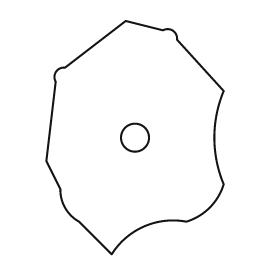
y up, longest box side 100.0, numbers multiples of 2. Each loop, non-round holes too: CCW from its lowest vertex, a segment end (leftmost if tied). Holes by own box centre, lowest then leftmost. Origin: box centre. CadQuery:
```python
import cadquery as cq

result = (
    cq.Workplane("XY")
    .moveTo(-10.0, -50.0)
    .threePointArc((4.0, -38.0), (22.0, -36.0))
    .threePointArc((32.0, -30.0), (38.0, -20.0))
    .threePointArc((34.0, 0.0), (38.0, 20.0))
    .lineTo(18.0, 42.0)
    .threePointArc((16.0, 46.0), (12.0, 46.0))
    .lineTo(-4.0, 50.0)
    .lineTo(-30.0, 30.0)
    .threePointArc((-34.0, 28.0), (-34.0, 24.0))
    .lineTo(-38.0, -10.0)
    .lineTo(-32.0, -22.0)
    .threePointArc((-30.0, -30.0), (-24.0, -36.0))
    .close()
    .moveTo(0.0, 0.0)
    .circle(6.0)
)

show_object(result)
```